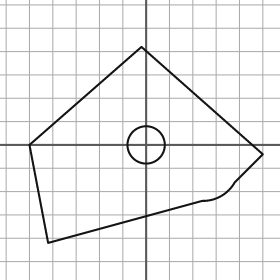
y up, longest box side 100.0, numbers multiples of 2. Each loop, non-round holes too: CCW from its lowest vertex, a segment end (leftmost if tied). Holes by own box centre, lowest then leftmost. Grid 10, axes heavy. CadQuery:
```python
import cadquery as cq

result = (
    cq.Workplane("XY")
    .moveTo(-42.0, -42.0)
    .lineTo(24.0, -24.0)
    .threePointArc((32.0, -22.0), (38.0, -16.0))
    .lineTo(50.0, -4.0)
    .lineTo(-2.0, 42.0)
    .lineTo(-50.0, 0.0)
    .close()
    .moveTo(0.0, 0.0)
    .circle(8.0)
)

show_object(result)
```